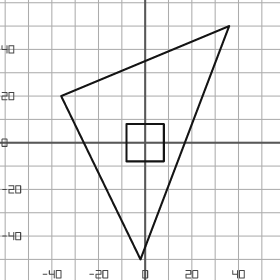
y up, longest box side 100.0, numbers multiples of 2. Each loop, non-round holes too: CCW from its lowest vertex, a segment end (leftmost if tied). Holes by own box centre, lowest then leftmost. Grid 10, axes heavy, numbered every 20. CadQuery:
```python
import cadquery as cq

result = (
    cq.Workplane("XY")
    .moveTo(-2.0, -50.0)
    .lineTo(36.0, 50.0)
    .lineTo(-36.0, 20.0)
    .close()
    .moveTo(-8.0, -8.0)
    .lineTo(8.0, -8.0)
    .lineTo(8.0, 8.0)
    .lineTo(-8.0, 8.0)
    .close()
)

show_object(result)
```